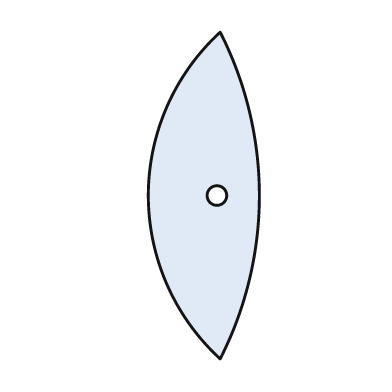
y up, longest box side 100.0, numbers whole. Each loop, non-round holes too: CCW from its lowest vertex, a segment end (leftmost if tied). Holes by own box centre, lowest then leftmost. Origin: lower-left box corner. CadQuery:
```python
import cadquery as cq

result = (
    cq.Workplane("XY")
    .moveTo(22.0, 0.0)
    .threePointArc((34.0, 50.0), (22.0, 100.0))
    .threePointArc((0.0, 50.0), (22.0, 0.0))
    .close()
    .moveTo(21.0, 50.0)
    .circle(3.0)
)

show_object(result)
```